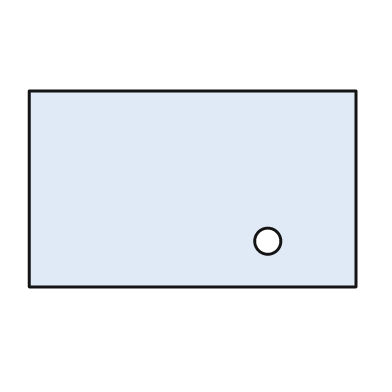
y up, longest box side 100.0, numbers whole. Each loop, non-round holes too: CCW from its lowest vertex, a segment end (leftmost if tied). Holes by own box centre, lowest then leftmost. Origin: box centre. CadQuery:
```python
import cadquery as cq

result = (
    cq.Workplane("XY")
    .moveTo(-50.0, -30.0)
    .lineTo(50.0, -30.0)
    .lineTo(50.0, 30.0)
    .lineTo(-50.0, 30.0)
    .close()
    .moveTo(23.0, -16.0)
    .circle(4.0)
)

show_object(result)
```